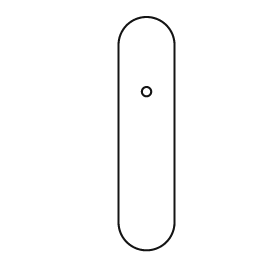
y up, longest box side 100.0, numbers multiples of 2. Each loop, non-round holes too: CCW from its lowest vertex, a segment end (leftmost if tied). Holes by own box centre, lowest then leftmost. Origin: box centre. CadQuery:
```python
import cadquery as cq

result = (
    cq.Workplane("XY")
    .moveTo(-12.0, -38.0)
    .threePointArc((0.0, -50.0), (12.0, -38.0))
    .lineTo(12.0, 38.0)
    .threePointArc((0.0, 50.0), (-12.0, 38.0))
    .close()
    .moveTo(0.0, 18.0)
    .circle(2.0)
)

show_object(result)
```